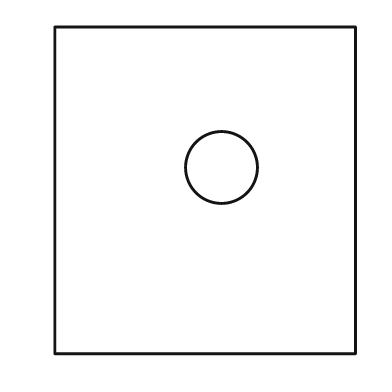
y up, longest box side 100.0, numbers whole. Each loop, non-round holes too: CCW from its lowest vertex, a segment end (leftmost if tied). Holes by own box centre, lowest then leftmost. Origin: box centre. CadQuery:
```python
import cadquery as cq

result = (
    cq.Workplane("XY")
    .moveTo(-46.0, -50.0)
    .lineTo(46.0, -50.0)
    .lineTo(46.0, 50.0)
    .lineTo(-46.0, 50.0)
    .close()
    .moveTo(5.0, 7.0)
    .circle(11.0)
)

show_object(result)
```